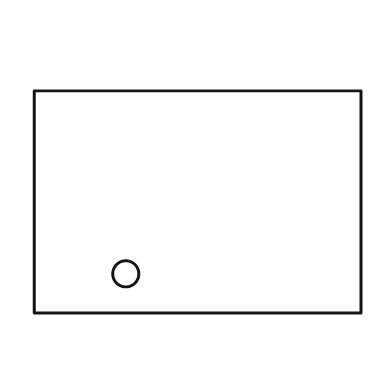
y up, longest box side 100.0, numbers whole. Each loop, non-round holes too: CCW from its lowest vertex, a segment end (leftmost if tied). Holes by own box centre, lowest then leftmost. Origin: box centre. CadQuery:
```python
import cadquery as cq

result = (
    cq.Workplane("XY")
    .moveTo(-50.0, -34.0)
    .lineTo(50.0, -34.0)
    .lineTo(50.0, 34.0)
    .lineTo(-50.0, 34.0)
    .close()
    .moveTo(-22.0, -22.0)
    .circle(4.0)
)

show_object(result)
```